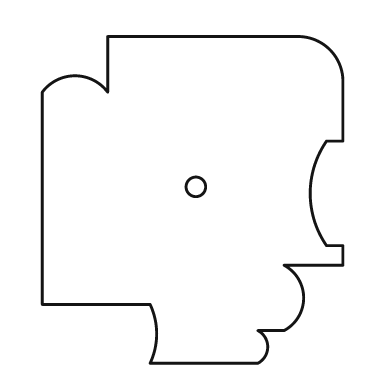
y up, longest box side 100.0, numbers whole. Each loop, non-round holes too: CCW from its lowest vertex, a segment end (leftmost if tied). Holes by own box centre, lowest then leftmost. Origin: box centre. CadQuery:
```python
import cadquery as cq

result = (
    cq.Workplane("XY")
    .moveTo(-13.0, -50.0)
    .lineTo(20.0, -50.0)
    .threePointArc((23.0, -45.0), (20.0, -40.0))
    .lineTo(28.0, -40.0)
    .threePointArc((34.0, -30.0), (28.0, -20.0))
    .lineTo(46.0, -20.0)
    .lineTo(46.0, -14.0)
    .lineTo(41.0, -14.0)
    .threePointArc((36.0, 2.0), (41.0, 18.0))
    .lineTo(46.0, 18.0)
    .lineTo(46.0, 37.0)
    .threePointArc((42.0, 46.0), (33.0, 50.0))
    .lineTo(-26.0, 50.0)
    .lineTo(-26.0, 33.0)
    .threePointArc((-36.0, 38.0), (-46.0, 33.0))
    .lineTo(-46.0, -32.0)
    .lineTo(-13.0, -32.0)
    .threePointArc((-11.0, -41.0), (-13.0, -50.0))
    .close()
    .moveTo(1.0, 4.0)
    .circle(3.0)
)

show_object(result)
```